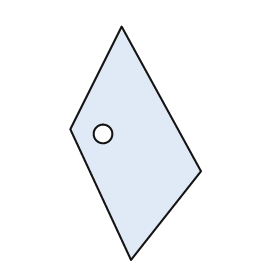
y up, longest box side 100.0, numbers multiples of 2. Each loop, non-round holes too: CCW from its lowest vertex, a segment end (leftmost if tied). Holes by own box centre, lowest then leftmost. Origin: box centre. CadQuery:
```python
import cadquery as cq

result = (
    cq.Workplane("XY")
    .moveTo(-2.0, -50.0)
    .lineTo(28.0, -12.0)
    .lineTo(-6.0, 50.0)
    .lineTo(-28.0, 6.0)
    .close()
    .moveTo(-14.0, 4.0)
    .circle(4.0)
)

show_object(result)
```